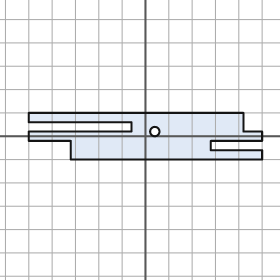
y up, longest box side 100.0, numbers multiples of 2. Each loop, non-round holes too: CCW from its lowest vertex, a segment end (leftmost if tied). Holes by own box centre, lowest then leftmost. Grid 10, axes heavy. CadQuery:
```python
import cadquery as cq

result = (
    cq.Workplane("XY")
    .moveTo(-32.0, -10.0)
    .lineTo(50.0, -10.0)
    .lineTo(50.0, -6.0)
    .lineTo(28.0, -6.0)
    .lineTo(28.0, -2.0)
    .lineTo(50.0, -2.0)
    .lineTo(50.0, 2.0)
    .lineTo(42.0, 2.0)
    .lineTo(42.0, 10.0)
    .lineTo(-50.0, 10.0)
    .lineTo(-50.0, 6.0)
    .lineTo(-6.0, 6.0)
    .lineTo(-6.0, 2.0)
    .lineTo(-50.0, 2.0)
    .lineTo(-50.0, -2.0)
    .lineTo(-32.0, -2.0)
    .close()
    .moveTo(4.0, 2.0)
    .circle(2.0)
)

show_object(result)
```